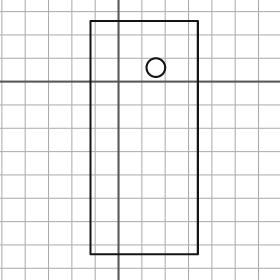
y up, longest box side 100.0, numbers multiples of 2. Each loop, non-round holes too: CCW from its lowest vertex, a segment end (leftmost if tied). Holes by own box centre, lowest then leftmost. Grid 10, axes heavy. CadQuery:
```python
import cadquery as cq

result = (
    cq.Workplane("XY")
    .moveTo(-12.0, -74.0)
    .lineTo(34.0, -74.0)
    .lineTo(34.0, 26.0)
    .lineTo(-12.0, 26.0)
    .close()
    .moveTo(16.0, 6.0)
    .circle(4.0)
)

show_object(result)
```